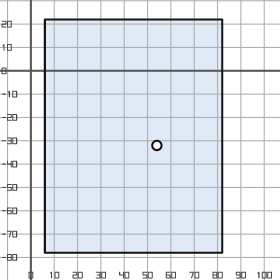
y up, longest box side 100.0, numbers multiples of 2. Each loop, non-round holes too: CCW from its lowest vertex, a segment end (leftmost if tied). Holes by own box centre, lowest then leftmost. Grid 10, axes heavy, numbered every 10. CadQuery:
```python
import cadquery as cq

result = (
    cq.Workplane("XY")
    .moveTo(6.0, -78.0)
    .lineTo(82.0, -78.0)
    .lineTo(82.0, 22.0)
    .lineTo(6.0, 22.0)
    .close()
    .moveTo(54.0, -32.0)
    .circle(2.0)
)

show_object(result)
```